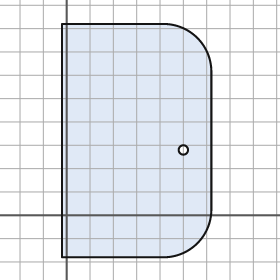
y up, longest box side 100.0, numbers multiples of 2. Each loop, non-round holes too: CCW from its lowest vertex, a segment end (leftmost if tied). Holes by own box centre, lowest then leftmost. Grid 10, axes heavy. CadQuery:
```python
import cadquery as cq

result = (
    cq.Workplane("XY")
    .moveTo(-2.0, -18.0)
    .lineTo(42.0, -18.0)
    .threePointArc((56.0, -12.0), (62.0, 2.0))
    .lineTo(62.0, 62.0)
    .threePointArc((56.0, 76.0), (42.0, 82.0))
    .lineTo(-2.0, 82.0)
    .close()
    .moveTo(50.0, 28.0)
    .circle(2.0)
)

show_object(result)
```